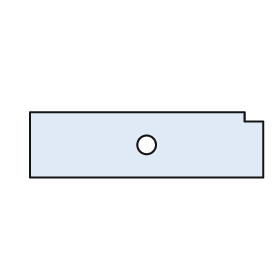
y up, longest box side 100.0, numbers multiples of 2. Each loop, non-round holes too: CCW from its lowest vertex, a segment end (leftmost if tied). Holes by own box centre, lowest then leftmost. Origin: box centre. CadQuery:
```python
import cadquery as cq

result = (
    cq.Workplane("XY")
    .moveTo(-50.0, -14.0)
    .lineTo(50.0, -14.0)
    .lineTo(50.0, 10.0)
    .lineTo(42.0, 10.0)
    .lineTo(42.0, 14.0)
    .lineTo(-50.0, 14.0)
    .close()
    .moveTo(0.0, 0.0)
    .circle(4.0)
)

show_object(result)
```